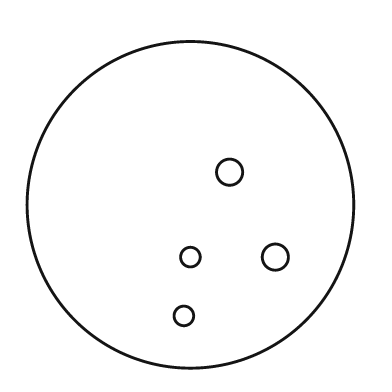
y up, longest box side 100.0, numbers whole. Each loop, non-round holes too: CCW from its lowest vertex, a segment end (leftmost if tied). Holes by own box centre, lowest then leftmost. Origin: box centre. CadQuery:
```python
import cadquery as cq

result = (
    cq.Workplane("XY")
    .moveTo(0.0, 0.0)
    .circle(50.0)
    .moveTo(-2.0, -34.0)
    .circle(3.0)
    .moveTo(0.0, -16.0)
    .circle(3.0)
    .moveTo(26.0, -16.0)
    .circle(4.0)
    .moveTo(12.0, 10.0)
    .circle(4.0)
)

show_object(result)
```